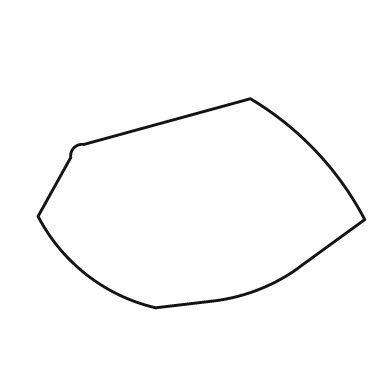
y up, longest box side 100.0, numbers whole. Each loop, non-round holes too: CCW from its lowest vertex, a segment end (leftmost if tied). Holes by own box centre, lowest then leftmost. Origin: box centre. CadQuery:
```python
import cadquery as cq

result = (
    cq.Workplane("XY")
    .moveTo(-14.0, -32.0)
    .lineTo(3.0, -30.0)
    .threePointArc((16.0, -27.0), (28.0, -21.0))
    .lineTo(50.0, -5.0)
    .threePointArc((35.0, 16.0), (15.0, 32.0))
    .lineTo(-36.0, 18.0)
    .threePointArc((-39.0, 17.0), (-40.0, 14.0))
    .lineTo(-50.0, -4.0)
    .threePointArc((-35.0, -22.0), (-14.0, -32.0))
    .close()
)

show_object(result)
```